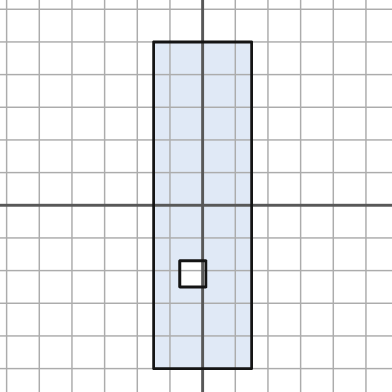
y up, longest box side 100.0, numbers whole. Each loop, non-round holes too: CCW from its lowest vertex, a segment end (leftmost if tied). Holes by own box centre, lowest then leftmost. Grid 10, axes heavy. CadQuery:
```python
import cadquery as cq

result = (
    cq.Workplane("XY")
    .moveTo(-15.0, -50.0)
    .lineTo(15.0, -50.0)
    .lineTo(15.0, 50.0)
    .lineTo(-15.0, 50.0)
    .close()
    .moveTo(-7.0, -25.0)
    .lineTo(1.0, -25.0)
    .lineTo(1.0, -17.0)
    .lineTo(-7.0, -17.0)
    .close()
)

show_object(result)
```